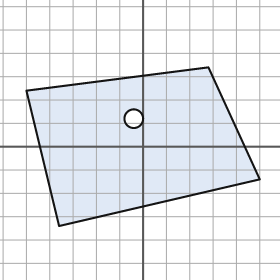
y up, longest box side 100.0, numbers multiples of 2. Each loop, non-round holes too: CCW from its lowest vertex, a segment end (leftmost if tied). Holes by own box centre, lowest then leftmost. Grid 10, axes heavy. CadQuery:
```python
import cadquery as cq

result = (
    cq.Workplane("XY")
    .moveTo(-36.0, -34.0)
    .lineTo(50.0, -14.0)
    .lineTo(28.0, 34.0)
    .lineTo(-50.0, 24.0)
    .close()
    .moveTo(-4.0, 12.0)
    .circle(4.0)
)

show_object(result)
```